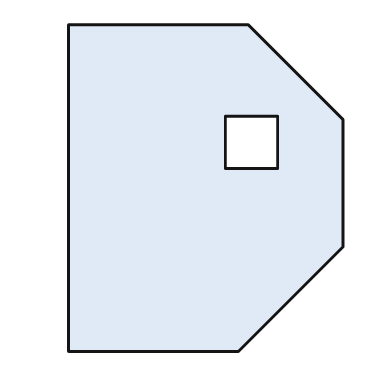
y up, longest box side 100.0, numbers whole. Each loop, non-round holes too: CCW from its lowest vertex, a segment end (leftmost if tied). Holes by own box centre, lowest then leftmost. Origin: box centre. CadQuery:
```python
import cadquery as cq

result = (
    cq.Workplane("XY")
    .moveTo(-42.0, -50.0)
    .lineTo(10.0, -50.0)
    .lineTo(42.0, -18.0)
    .lineTo(42.0, 21.0)
    .lineTo(13.0, 50.0)
    .lineTo(-42.0, 50.0)
    .close()
    .moveTo(6.0, 6.0)
    .lineTo(22.0, 6.0)
    .lineTo(22.0, 22.0)
    .lineTo(6.0, 22.0)
    .close()
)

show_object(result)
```